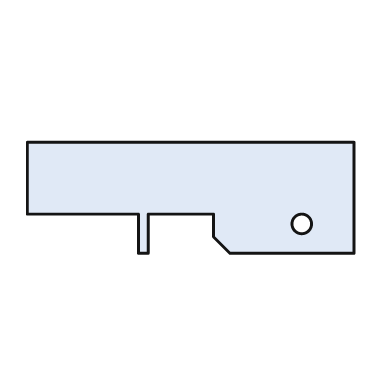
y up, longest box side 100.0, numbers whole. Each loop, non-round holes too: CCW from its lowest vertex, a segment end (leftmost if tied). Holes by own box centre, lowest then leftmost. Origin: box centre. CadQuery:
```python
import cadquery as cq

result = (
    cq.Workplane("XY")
    .moveTo(-16.0, -17.0)
    .lineTo(-13.0, -17.0)
    .lineTo(-13.0, -5.0)
    .lineTo(7.0, -5.0)
    .lineTo(7.0, -12.0)
    .lineTo(12.0, -17.0)
    .lineTo(50.0, -17.0)
    .lineTo(50.0, 17.0)
    .lineTo(-50.0, 17.0)
    .lineTo(-50.0, -5.0)
    .lineTo(-16.0, -5.0)
    .close()
    .moveTo(34.0, -8.0)
    .circle(3.0)
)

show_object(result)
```